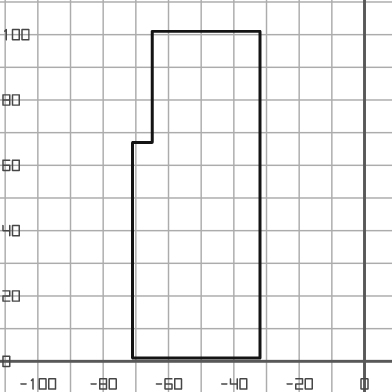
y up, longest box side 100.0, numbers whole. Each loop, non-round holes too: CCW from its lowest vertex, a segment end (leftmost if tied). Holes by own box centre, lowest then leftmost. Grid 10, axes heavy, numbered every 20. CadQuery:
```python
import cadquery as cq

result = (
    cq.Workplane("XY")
    .moveTo(-71.0, 1.0)
    .lineTo(-32.0, 1.0)
    .lineTo(-32.0, 101.0)
    .lineTo(-65.0, 101.0)
    .lineTo(-65.0, 67.0)
    .lineTo(-71.0, 67.0)
    .close()
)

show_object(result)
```